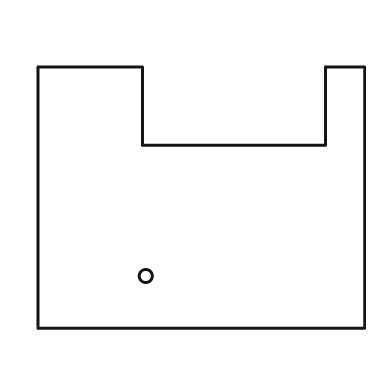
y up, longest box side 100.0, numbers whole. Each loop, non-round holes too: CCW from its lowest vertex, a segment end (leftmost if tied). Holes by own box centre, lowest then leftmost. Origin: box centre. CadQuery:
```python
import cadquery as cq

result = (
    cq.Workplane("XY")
    .moveTo(-50.0, -40.0)
    .lineTo(50.0, -40.0)
    .lineTo(50.0, 40.0)
    .lineTo(38.0, 40.0)
    .lineTo(38.0, 16.0)
    .lineTo(-18.0, 16.0)
    .lineTo(-18.0, 40.0)
    .lineTo(-50.0, 40.0)
    .close()
    .moveTo(-17.0, -24.0)
    .circle(2.0)
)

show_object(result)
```